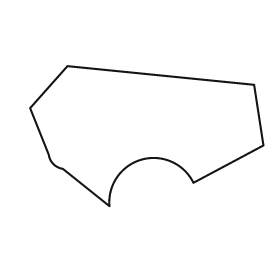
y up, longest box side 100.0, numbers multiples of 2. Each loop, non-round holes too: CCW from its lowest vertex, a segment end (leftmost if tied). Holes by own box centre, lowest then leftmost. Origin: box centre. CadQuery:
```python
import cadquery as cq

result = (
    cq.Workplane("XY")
    .moveTo(-16.0, -30.0)
    .threePointArc((-2.0, -10.0), (20.0, -20.0))
    .lineTo(50.0, -4.0)
    .lineTo(46.0, 22.0)
    .lineTo(-34.0, 30.0)
    .lineTo(-50.0, 12.0)
    .lineTo(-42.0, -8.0)
    .threePointArc((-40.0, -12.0), (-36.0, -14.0))
    .close()
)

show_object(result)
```